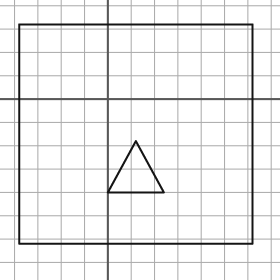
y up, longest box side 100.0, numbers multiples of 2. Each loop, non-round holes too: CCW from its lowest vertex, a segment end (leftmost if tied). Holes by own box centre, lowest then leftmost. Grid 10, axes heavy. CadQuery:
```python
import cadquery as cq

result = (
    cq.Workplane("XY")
    .moveTo(-38.0, -62.0)
    .lineTo(62.0, -62.0)
    .lineTo(62.0, 32.0)
    .lineTo(-38.0, 32.0)
    .close()
    .moveTo(0.0, -40.0)
    .lineTo(24.0, -40.0)
    .lineTo(12.0, -18.0)
    .close()
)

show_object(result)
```